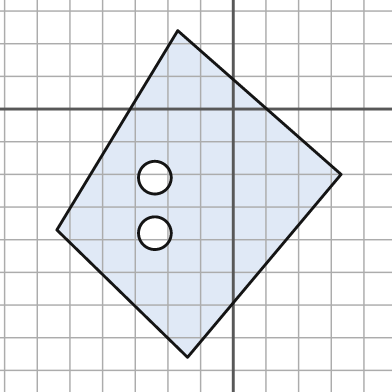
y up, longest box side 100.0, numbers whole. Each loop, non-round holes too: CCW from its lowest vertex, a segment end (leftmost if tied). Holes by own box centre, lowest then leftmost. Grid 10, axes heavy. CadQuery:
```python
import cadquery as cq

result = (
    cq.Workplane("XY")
    .moveTo(-14.0, -76.0)
    .lineTo(33.0, -20.0)
    .lineTo(-17.0, 24.0)
    .lineTo(-54.0, -37.0)
    .close()
    .moveTo(-24.0, -38.0)
    .circle(5.0)
    .moveTo(-24.0, -21.0)
    .circle(5.0)
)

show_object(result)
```